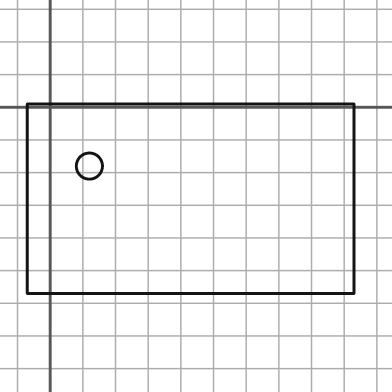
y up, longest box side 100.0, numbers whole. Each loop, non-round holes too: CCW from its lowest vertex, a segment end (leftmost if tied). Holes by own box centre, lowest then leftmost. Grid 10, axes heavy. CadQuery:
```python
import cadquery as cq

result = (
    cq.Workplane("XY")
    .moveTo(-7.0, -57.0)
    .lineTo(93.0, -57.0)
    .lineTo(93.0, 1.0)
    .lineTo(-7.0, 1.0)
    .close()
    .moveTo(12.0, -18.0)
    .circle(4.0)
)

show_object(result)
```